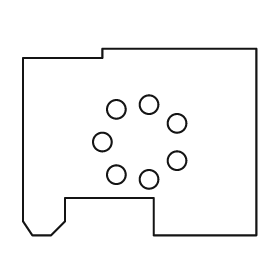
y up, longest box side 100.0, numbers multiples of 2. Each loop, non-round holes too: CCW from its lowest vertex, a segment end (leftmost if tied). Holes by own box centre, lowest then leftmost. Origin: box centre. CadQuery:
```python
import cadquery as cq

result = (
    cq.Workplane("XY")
    .moveTo(-46.0, -40.0)
    .lineTo(-38.0, -40.0)
    .lineTo(-32.0, -34.0)
    .lineTo(-32.0, -24.0)
    .lineTo(6.0, -24.0)
    .lineTo(6.0, -40.0)
    .lineTo(50.0, -40.0)
    .lineTo(50.0, 40.0)
    .lineTo(-16.0, 40.0)
    .lineTo(-16.0, 36.0)
    .lineTo(-50.0, 36.0)
    .lineTo(-50.0, -34.0)
    .close()
    .moveTo(4.0, -16.0)
    .circle(4.0)
    .moveTo(-10.0, -14.0)
    .circle(4.0)
    .moveTo(16.0, -8.0)
    .circle(4.0)
    .moveTo(-16.0, 0.0)
    .circle(4.0)
    .moveTo(16.0, 8.0)
    .circle(4.0)
    .moveTo(-10.0, 14.0)
    .circle(4.0)
    .moveTo(4.0, 16.0)
    .circle(4.0)
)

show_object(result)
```